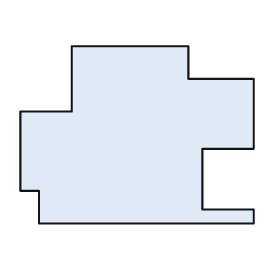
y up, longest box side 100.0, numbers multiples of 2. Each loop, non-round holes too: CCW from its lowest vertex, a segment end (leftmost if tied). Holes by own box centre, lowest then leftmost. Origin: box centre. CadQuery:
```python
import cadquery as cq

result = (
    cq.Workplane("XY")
    .moveTo(-42.0, -38.0)
    .lineTo(50.0, -38.0)
    .lineTo(50.0, -32.0)
    .lineTo(28.0, -32.0)
    .lineTo(28.0, -6.0)
    .lineTo(50.0, -6.0)
    .lineTo(50.0, 24.0)
    .lineTo(22.0, 24.0)
    .lineTo(22.0, 38.0)
    .lineTo(-28.0, 38.0)
    .lineTo(-28.0, 10.0)
    .lineTo(-50.0, 10.0)
    .lineTo(-50.0, -24.0)
    .lineTo(-42.0, -24.0)
    .close()
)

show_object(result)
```